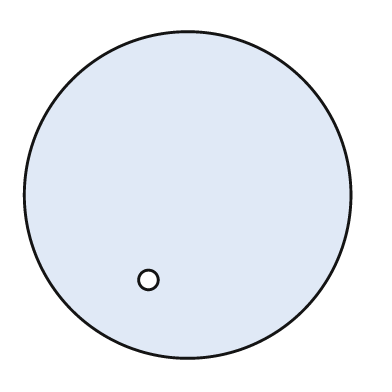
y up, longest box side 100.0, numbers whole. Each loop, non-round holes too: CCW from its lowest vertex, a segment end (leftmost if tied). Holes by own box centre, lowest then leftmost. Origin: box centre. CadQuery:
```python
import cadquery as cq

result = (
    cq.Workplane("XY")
    .moveTo(0.0, 0.0)
    .circle(50.0)
    .moveTo(-12.0, -26.0)
    .circle(3.0)
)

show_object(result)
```